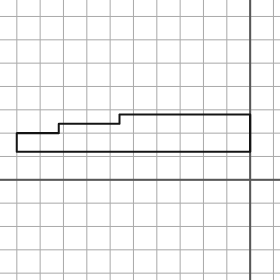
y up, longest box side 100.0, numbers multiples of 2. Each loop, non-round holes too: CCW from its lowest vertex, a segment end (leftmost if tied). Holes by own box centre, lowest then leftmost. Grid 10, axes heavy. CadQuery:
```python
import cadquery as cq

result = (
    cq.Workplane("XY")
    .moveTo(-100.0, 12.0)
    .lineTo(0.0, 12.0)
    .lineTo(0.0, 28.0)
    .lineTo(-56.0, 28.0)
    .lineTo(-56.0, 24.0)
    .lineTo(-82.0, 24.0)
    .lineTo(-82.0, 20.0)
    .lineTo(-100.0, 20.0)
    .close()
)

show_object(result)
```